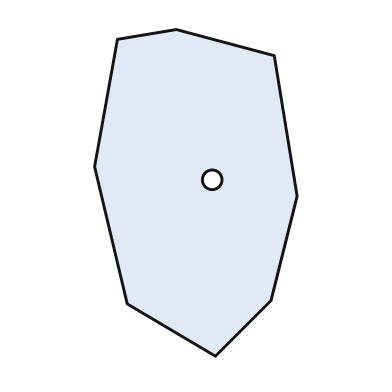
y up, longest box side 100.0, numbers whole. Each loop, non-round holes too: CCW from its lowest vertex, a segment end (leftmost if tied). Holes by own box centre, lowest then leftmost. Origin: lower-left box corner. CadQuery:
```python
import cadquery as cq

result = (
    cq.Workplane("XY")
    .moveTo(37.0, 0.0)
    .lineTo(54.0, 17.0)
    .lineTo(62.0, 49.0)
    .lineTo(55.0, 92.0)
    .lineTo(25.0, 100.0)
    .lineTo(7.0, 97.0)
    .lineTo(0.0, 58.0)
    .lineTo(10.0, 16.0)
    .close()
    .moveTo(36.0, 54.0)
    .circle(3.0)
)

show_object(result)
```